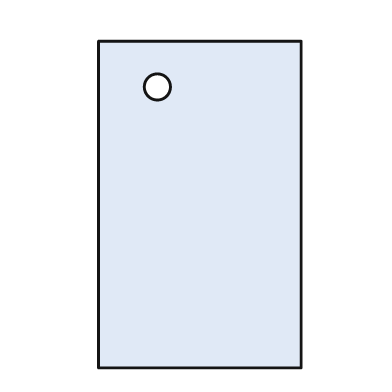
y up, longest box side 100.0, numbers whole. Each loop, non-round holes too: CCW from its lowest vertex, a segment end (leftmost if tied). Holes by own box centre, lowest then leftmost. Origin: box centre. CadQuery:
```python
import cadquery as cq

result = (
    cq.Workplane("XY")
    .moveTo(-31.0, -50.0)
    .lineTo(31.0, -50.0)
    .lineTo(31.0, 50.0)
    .lineTo(-31.0, 50.0)
    .close()
    .moveTo(-13.0, 36.0)
    .circle(4.0)
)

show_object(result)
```